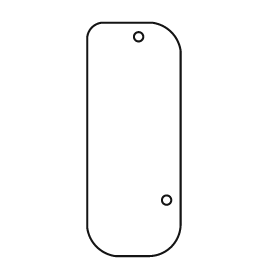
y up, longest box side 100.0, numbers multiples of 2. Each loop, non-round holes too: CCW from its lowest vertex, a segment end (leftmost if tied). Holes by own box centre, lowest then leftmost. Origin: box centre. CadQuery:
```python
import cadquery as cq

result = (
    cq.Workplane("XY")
    .moveTo(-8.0, -50.0)
    .lineTo(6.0, -50.0)
    .threePointArc((16.0, -46.0), (20.0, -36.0))
    .lineTo(20.0, 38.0)
    .threePointArc((16.0, 46.0), (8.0, 50.0))
    .lineTo(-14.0, 50.0)
    .threePointArc((-18.0, 48.0), (-20.0, 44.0))
    .lineTo(-20.0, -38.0)
    .threePointArc((-16.0, -46.0), (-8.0, -50.0))
    .close()
    .moveTo(14.0, -26.0)
    .circle(2.0)
    .moveTo(2.0, 44.0)
    .circle(2.0)
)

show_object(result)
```